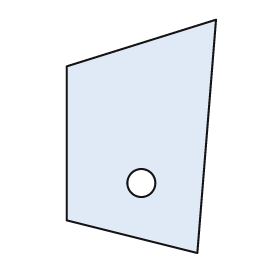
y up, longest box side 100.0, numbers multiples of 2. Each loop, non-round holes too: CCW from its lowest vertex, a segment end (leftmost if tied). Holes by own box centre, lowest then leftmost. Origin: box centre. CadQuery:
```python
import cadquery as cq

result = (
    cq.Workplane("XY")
    .moveTo(24.0, -50.0)
    .lineTo(32.0, 50.0)
    .lineTo(-32.0, 30.0)
    .lineTo(-32.0, -36.0)
    .close()
    .moveTo(0.0, -20.0)
    .circle(6.0)
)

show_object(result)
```